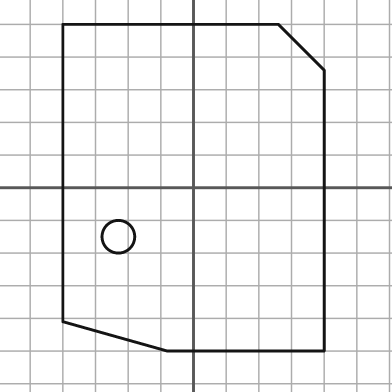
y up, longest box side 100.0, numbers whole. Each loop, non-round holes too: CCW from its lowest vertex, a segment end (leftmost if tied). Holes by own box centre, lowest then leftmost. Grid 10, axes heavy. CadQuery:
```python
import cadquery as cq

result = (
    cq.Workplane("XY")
    .moveTo(-8.0, -50.0)
    .lineTo(40.0, -50.0)
    .lineTo(40.0, 36.0)
    .lineTo(26.0, 50.0)
    .lineTo(-40.0, 50.0)
    .lineTo(-40.0, -41.0)
    .close()
    .moveTo(-23.0, -15.0)
    .circle(5.0)
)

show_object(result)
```